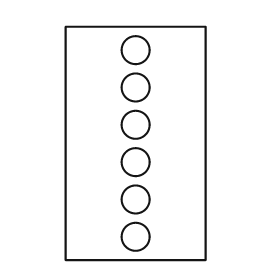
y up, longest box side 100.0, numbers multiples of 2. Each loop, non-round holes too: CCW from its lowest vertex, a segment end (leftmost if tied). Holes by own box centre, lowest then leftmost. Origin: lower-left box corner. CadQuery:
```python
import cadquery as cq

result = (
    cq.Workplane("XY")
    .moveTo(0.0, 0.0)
    .lineTo(60.0, 0.0)
    .lineTo(60.0, 100.0)
    .lineTo(0.0, 100.0)
    .close()
    .moveTo(30.0, 10.0)
    .circle(6.0)
    .moveTo(30.0, 26.0)
    .circle(6.0)
    .moveTo(30.0, 42.0)
    .circle(6.0)
    .moveTo(30.0, 58.0)
    .circle(6.0)
    .moveTo(30.0, 74.0)
    .circle(6.0)
    .moveTo(30.0, 90.0)
    .circle(6.0)
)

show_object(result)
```